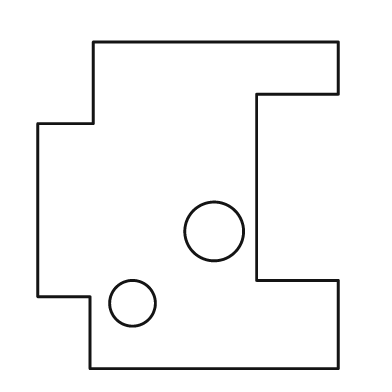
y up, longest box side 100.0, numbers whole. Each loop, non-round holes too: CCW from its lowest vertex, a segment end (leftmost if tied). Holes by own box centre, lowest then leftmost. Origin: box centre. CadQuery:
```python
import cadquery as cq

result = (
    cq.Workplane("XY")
    .moveTo(-30.0, -50.0)
    .lineTo(46.0, -50.0)
    .lineTo(46.0, -23.0)
    .lineTo(21.0, -23.0)
    .lineTo(21.0, 34.0)
    .lineTo(46.0, 34.0)
    .lineTo(46.0, 50.0)
    .lineTo(-29.0, 50.0)
    .lineTo(-29.0, 25.0)
    .lineTo(-46.0, 25.0)
    .lineTo(-46.0, -28.0)
    .lineTo(-30.0, -28.0)
    .close()
    .moveTo(-17.0, -30.0)
    .circle(7.0)
    .moveTo(8.0, -8.0)
    .circle(9.0)
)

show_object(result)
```